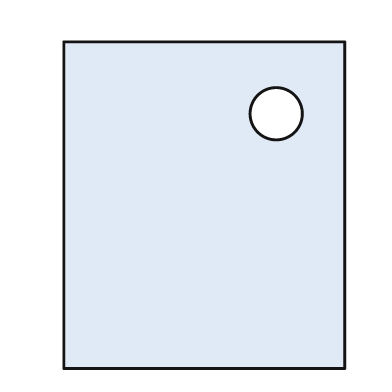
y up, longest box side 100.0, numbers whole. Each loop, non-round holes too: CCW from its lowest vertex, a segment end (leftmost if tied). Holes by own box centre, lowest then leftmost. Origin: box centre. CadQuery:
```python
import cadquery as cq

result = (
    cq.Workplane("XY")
    .moveTo(-43.0, -50.0)
    .lineTo(43.0, -50.0)
    .lineTo(43.0, 50.0)
    .lineTo(-43.0, 50.0)
    .close()
    .moveTo(22.0, 28.0)
    .circle(8.0)
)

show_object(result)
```